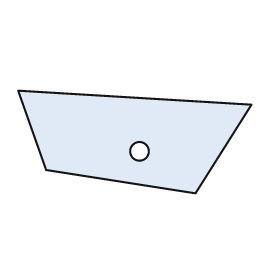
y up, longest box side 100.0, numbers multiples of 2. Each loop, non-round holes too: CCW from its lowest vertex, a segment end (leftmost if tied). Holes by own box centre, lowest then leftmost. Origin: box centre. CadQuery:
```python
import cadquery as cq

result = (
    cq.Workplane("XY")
    .moveTo(26.0, -22.0)
    .lineTo(50.0, 16.0)
    .lineTo(-50.0, 22.0)
    .lineTo(-38.0, -12.0)
    .close()
    .moveTo(2.0, -4.0)
    .circle(4.0)
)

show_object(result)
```